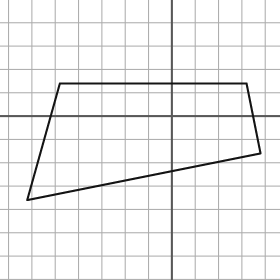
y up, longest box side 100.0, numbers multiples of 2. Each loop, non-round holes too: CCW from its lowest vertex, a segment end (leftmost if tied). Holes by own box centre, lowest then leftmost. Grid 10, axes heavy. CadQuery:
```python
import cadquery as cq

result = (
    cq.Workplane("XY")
    .moveTo(-62.0, -36.0)
    .lineTo(38.0, -16.0)
    .lineTo(32.0, 14.0)
    .lineTo(-48.0, 14.0)
    .close()
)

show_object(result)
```